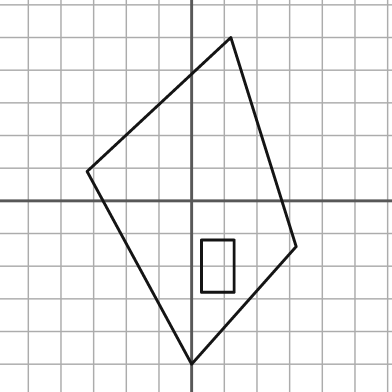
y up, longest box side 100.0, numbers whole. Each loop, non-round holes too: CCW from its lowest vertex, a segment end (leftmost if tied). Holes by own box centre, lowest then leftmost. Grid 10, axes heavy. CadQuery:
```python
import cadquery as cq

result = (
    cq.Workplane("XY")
    .moveTo(0.0, -50.0)
    .lineTo(32.0, -14.0)
    .lineTo(12.0, 50.0)
    .lineTo(-32.0, 9.0)
    .close()
    .moveTo(3.0, -28.0)
    .lineTo(13.0, -28.0)
    .lineTo(13.0, -12.0)
    .lineTo(3.0, -12.0)
    .close()
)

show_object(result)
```